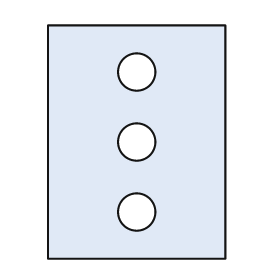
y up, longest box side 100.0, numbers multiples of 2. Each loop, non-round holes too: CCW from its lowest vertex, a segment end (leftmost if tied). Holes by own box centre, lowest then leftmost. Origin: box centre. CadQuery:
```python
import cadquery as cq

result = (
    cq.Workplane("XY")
    .moveTo(-38.0, -50.0)
    .lineTo(38.0, -50.0)
    .lineTo(38.0, 50.0)
    .lineTo(-38.0, 50.0)
    .close()
    .moveTo(0.0, -30.0)
    .circle(8.0)
    .moveTo(0.0, 0.0)
    .circle(8.0)
    .moveTo(0.0, 30.0)
    .circle(8.0)
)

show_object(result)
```